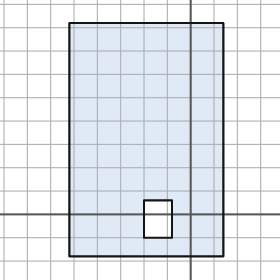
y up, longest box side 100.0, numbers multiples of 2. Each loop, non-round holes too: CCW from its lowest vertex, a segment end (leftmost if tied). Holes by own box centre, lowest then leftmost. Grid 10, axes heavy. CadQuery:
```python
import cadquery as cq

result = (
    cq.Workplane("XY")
    .moveTo(-52.0, -18.0)
    .lineTo(14.0, -18.0)
    .lineTo(14.0, 82.0)
    .lineTo(-52.0, 82.0)
    .close()
    .moveTo(-20.0, -10.0)
    .lineTo(-8.0, -10.0)
    .lineTo(-8.0, 6.0)
    .lineTo(-20.0, 6.0)
    .close()
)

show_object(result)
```